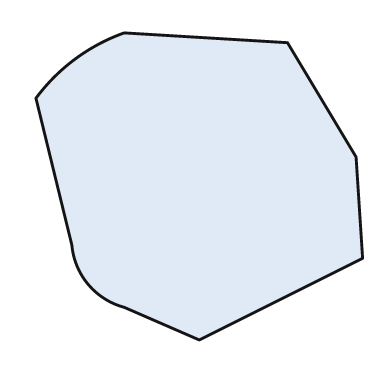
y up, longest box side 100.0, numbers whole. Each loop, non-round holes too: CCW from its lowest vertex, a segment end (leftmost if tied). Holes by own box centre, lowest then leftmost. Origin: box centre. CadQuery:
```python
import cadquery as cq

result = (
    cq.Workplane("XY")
    .moveTo(0.0, -47.0)
    .lineTo(50.0, -22.0)
    .lineTo(48.0, 9.0)
    .lineTo(27.0, 44.0)
    .lineTo(-23.0, 47.0)
    .threePointArc((-38.0, 39.0), (-50.0, 27.0))
    .lineTo(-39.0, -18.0)
    .threePointArc((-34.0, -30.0), (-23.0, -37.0))
    .close()
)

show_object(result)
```